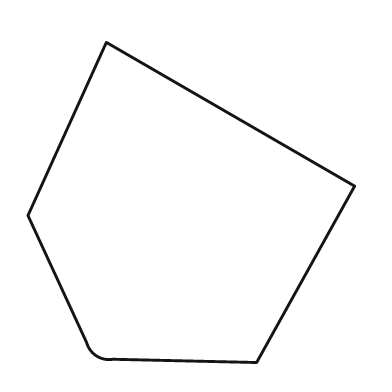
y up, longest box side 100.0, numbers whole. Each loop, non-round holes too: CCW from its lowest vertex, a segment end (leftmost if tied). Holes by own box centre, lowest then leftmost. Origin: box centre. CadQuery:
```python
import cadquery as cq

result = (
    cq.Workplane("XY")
    .moveTo(20.0, -49.0)
    .lineTo(50.0, 5.0)
    .lineTo(-26.0, 49.0)
    .lineTo(-50.0, -4.0)
    .lineTo(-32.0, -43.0)
    .threePointArc((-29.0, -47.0), (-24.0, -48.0))
    .close()
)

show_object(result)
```